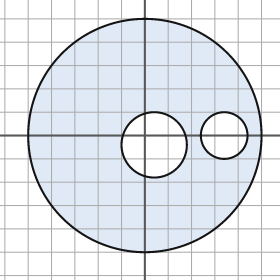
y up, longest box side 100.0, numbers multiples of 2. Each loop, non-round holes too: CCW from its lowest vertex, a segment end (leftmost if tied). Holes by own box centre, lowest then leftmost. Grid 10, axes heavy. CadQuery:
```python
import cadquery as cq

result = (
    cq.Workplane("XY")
    .moveTo(0.0, 0.0)
    .circle(50.0)
    .moveTo(4.0, -4.0)
    .circle(14.0)
    .moveTo(34.0, 0.0)
    .circle(10.0)
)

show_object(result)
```